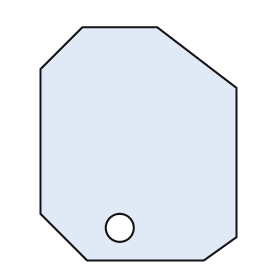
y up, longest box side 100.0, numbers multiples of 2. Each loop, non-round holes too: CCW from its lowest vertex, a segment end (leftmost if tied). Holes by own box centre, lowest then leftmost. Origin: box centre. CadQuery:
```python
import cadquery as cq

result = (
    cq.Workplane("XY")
    .moveTo(-22.0, -50.0)
    .lineTo(28.0, -50.0)
    .lineTo(42.0, -40.0)
    .lineTo(42.0, 24.0)
    .lineTo(8.0, 50.0)
    .lineTo(-24.0, 50.0)
    .lineTo(-42.0, 32.0)
    .lineTo(-42.0, -30.0)
    .close()
    .moveTo(-8.0, -36.0)
    .circle(6.0)
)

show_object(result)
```